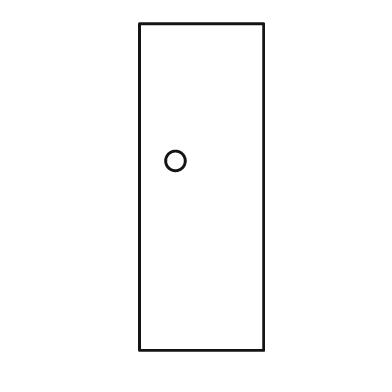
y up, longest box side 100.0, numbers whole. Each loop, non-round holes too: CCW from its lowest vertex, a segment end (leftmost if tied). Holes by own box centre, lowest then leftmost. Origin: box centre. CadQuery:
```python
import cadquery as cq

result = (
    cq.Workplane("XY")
    .moveTo(-19.0, -50.0)
    .lineTo(19.0, -50.0)
    .lineTo(19.0, 50.0)
    .lineTo(-19.0, 50.0)
    .close()
    .moveTo(-8.0, 8.0)
    .circle(3.0)
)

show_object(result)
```